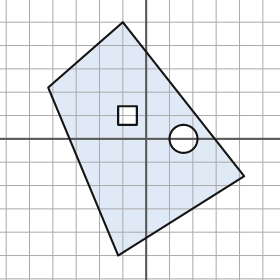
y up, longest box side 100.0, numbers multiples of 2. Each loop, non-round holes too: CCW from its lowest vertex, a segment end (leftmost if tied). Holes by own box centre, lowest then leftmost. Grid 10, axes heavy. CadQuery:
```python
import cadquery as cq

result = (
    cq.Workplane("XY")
    .moveTo(-12.0, -50.0)
    .lineTo(42.0, -16.0)
    .lineTo(-10.0, 50.0)
    .lineTo(-42.0, 22.0)
    .close()
    .moveTo(16.0, 0.0)
    .circle(6.0)
    .moveTo(-12.0, 6.0)
    .lineTo(-4.0, 6.0)
    .lineTo(-4.0, 14.0)
    .lineTo(-12.0, 14.0)
    .close()
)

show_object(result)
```